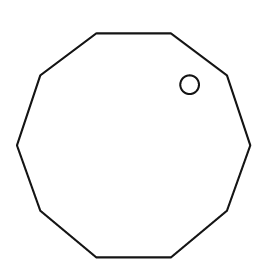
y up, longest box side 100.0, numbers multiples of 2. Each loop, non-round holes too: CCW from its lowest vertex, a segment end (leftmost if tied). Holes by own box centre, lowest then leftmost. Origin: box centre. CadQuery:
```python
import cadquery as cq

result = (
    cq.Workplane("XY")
    .moveTo(-16.0, -48.0)
    .lineTo(16.0, -48.0)
    .lineTo(40.0, -28.0)
    .lineTo(50.0, 0.0)
    .lineTo(40.0, 30.0)
    .lineTo(16.0, 48.0)
    .lineTo(-16.0, 48.0)
    .lineTo(-40.0, 30.0)
    .lineTo(-50.0, 0.0)
    .lineTo(-40.0, -28.0)
    .close()
    .moveTo(24.0, 26.0)
    .circle(4.0)
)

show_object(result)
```